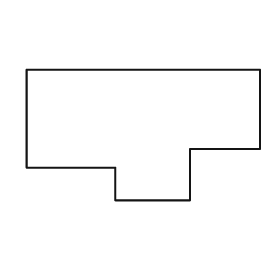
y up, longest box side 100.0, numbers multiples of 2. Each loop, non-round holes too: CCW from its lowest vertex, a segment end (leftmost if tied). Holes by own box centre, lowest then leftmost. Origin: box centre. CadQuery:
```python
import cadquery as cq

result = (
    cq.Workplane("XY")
    .moveTo(-12.0, -28.0)
    .lineTo(20.0, -28.0)
    .lineTo(20.0, -6.0)
    .lineTo(50.0, -6.0)
    .lineTo(50.0, 28.0)
    .lineTo(-50.0, 28.0)
    .lineTo(-50.0, -14.0)
    .lineTo(-12.0, -14.0)
    .close()
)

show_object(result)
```